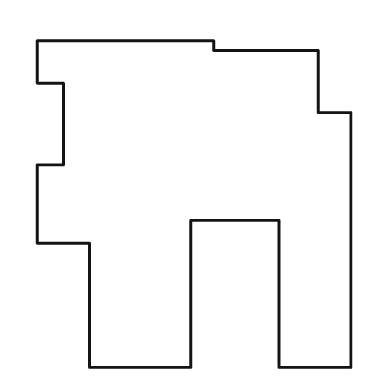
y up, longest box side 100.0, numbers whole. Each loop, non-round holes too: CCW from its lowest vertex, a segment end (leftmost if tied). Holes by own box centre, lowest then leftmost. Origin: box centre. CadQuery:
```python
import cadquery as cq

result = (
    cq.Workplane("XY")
    .moveTo(-32.0, -50.0)
    .lineTo(-1.0, -50.0)
    .lineTo(-1.0, -5.0)
    .lineTo(26.0, -5.0)
    .lineTo(26.0, -50.0)
    .lineTo(48.0, -50.0)
    .lineTo(48.0, 28.0)
    .lineTo(38.0, 28.0)
    .lineTo(38.0, 47.0)
    .lineTo(6.0, 47.0)
    .lineTo(6.0, 50.0)
    .lineTo(-48.0, 50.0)
    .lineTo(-48.0, 37.0)
    .lineTo(-40.0, 37.0)
    .lineTo(-40.0, 12.0)
    .lineTo(-48.0, 12.0)
    .lineTo(-48.0, -12.0)
    .lineTo(-32.0, -12.0)
    .close()
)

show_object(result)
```